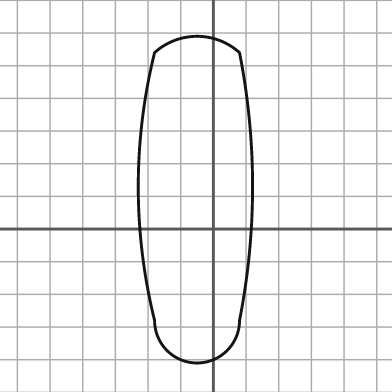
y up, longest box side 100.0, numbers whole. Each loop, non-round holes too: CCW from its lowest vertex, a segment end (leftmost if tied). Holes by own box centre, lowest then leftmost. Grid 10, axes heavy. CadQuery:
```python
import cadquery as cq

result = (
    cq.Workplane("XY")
    .moveTo(-18.0, -28.0)
    .threePointArc((-5.0, -41.0), (8.0, -28.0))
    .threePointArc((12.0, 13.0), (8.0, 54.0))
    .threePointArc((-5.0, 59.0), (-18.0, 54.0))
    .threePointArc((-23.0, 13.0), (-18.0, -28.0))
    .close()
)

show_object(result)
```